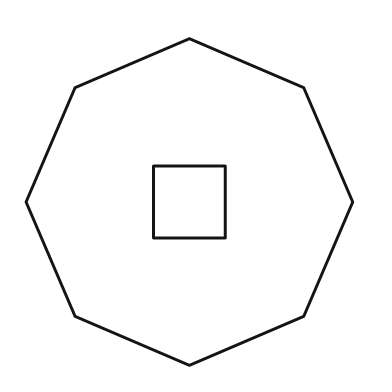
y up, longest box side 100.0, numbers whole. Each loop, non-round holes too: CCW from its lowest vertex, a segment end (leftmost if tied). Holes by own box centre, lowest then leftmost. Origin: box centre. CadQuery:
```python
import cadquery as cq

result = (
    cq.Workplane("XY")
    .moveTo(0.0, -50.0)
    .lineTo(35.0, -35.0)
    .lineTo(50.0, 0.0)
    .lineTo(35.0, 35.0)
    .lineTo(0.0, 50.0)
    .lineTo(-35.0, 35.0)
    .lineTo(-50.0, 0.0)
    .lineTo(-35.0, -35.0)
    .close()
    .moveTo(-11.0, -11.0)
    .lineTo(11.0, -11.0)
    .lineTo(11.0, 11.0)
    .lineTo(-11.0, 11.0)
    .close()
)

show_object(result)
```